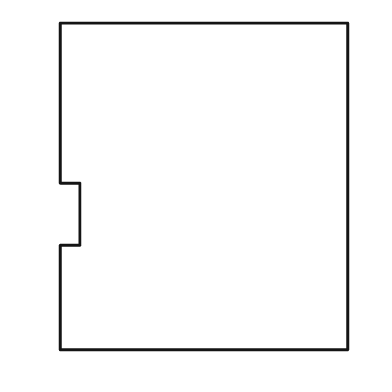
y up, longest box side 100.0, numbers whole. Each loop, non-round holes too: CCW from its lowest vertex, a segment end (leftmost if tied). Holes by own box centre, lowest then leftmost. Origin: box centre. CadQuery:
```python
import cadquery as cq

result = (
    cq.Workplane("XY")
    .moveTo(-44.0, -50.0)
    .lineTo(44.0, -50.0)
    .lineTo(44.0, 50.0)
    .lineTo(-44.0, 50.0)
    .lineTo(-44.0, 1.0)
    .lineTo(-38.0, 1.0)
    .lineTo(-38.0, -18.0)
    .lineTo(-44.0, -18.0)
    .close()
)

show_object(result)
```